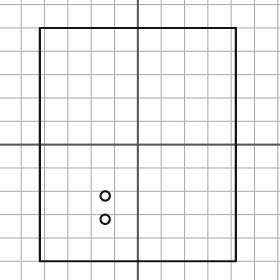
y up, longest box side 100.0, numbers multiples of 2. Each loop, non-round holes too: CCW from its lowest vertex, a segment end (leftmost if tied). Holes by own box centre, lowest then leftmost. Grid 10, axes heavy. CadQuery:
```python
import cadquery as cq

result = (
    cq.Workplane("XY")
    .moveTo(-42.0, -50.0)
    .lineTo(42.0, -50.0)
    .lineTo(42.0, 50.0)
    .lineTo(-42.0, 50.0)
    .close()
    .moveTo(-14.0, -32.0)
    .circle(2.0)
    .moveTo(-14.0, -22.0)
    .circle(2.0)
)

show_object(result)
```